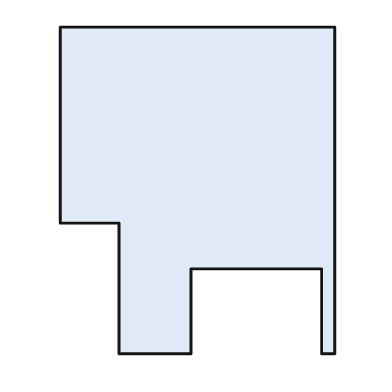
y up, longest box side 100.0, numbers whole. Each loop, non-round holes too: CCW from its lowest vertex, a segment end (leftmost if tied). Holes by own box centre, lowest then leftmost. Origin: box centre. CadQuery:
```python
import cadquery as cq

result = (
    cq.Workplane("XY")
    .moveTo(-24.0, -50.0)
    .lineTo(-2.0, -50.0)
    .lineTo(-2.0, -24.0)
    .lineTo(38.0, -24.0)
    .lineTo(38.0, -50.0)
    .lineTo(42.0, -50.0)
    .lineTo(42.0, 50.0)
    .lineTo(-42.0, 50.0)
    .lineTo(-42.0, -10.0)
    .lineTo(-24.0, -10.0)
    .close()
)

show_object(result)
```